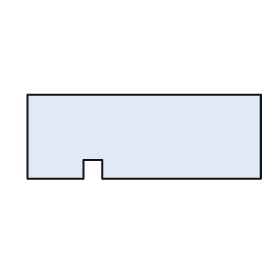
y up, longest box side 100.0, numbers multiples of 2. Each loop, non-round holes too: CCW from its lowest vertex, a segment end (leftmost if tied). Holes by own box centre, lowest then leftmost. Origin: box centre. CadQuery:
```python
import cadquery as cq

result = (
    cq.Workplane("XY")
    .moveTo(-50.0, -18.0)
    .lineTo(-26.0, -18.0)
    .lineTo(-26.0, -10.0)
    .lineTo(-18.0, -10.0)
    .lineTo(-18.0, -18.0)
    .lineTo(50.0, -18.0)
    .lineTo(50.0, 18.0)
    .lineTo(-50.0, 18.0)
    .close()
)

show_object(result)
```